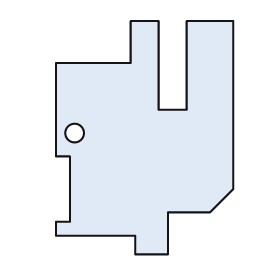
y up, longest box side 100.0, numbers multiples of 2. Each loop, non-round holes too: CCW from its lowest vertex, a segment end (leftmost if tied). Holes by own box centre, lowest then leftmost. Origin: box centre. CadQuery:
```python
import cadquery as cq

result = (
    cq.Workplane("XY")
    .moveTo(-4.0, -50.0)
    .lineTo(10.0, -50.0)
    .lineTo(10.0, -32.0)
    .lineTo(28.0, -32.0)
    .lineTo(38.0, -22.0)
    .lineTo(38.0, 50.0)
    .lineTo(18.0, 50.0)
    .lineTo(18.0, 12.0)
    .lineTo(6.0, 12.0)
    .lineTo(6.0, 50.0)
    .lineTo(-6.0, 50.0)
    .lineTo(-6.0, 32.0)
    .lineTo(-38.0, 32.0)
    .lineTo(-38.0, -8.0)
    .lineTo(-32.0, -8.0)
    .lineTo(-32.0, -36.0)
    .lineTo(-38.0, -36.0)
    .lineTo(-38.0, -42.0)
    .lineTo(-4.0, -42.0)
    .close()
    .moveTo(-30.0, 2.0)
    .circle(4.0)
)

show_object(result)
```